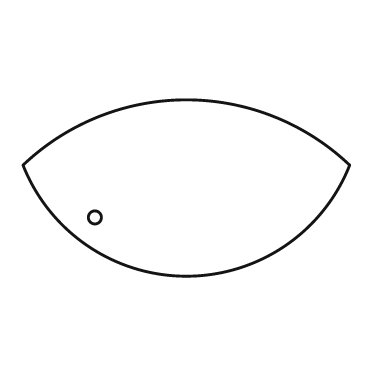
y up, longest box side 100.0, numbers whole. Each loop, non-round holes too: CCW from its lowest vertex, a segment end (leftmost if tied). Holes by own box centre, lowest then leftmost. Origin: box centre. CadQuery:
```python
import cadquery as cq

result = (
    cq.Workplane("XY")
    .moveTo(-50.0, 7.0)
    .threePointArc((0.0, -27.0), (50.0, 7.0))
    .threePointArc((0.0, 27.0), (-50.0, 7.0))
    .close()
    .moveTo(-28.0, -9.0)
    .circle(2.0)
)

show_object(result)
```